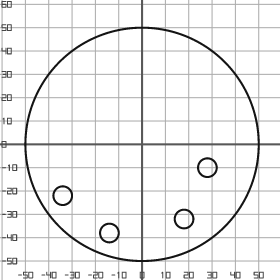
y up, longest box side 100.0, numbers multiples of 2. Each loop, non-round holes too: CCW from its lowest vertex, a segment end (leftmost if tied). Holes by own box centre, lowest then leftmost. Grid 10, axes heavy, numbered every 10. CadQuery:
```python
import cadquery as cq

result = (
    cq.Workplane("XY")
    .moveTo(0.0, 0.0)
    .circle(50.0)
    .moveTo(-14.0, -38.0)
    .circle(4.0)
    .moveTo(18.0, -32.0)
    .circle(4.0)
    .moveTo(-34.0, -22.0)
    .circle(4.0)
    .moveTo(28.0, -10.0)
    .circle(4.0)
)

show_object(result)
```